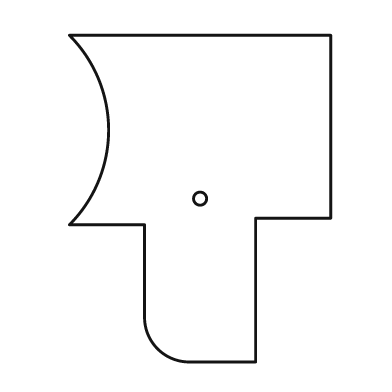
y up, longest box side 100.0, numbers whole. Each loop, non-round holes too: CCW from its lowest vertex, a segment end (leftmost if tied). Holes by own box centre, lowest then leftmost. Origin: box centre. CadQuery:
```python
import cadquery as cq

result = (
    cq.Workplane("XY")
    .moveTo(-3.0, -50.0)
    .lineTo(17.0, -50.0)
    .lineTo(17.0, -6.0)
    .lineTo(40.0, -6.0)
    .lineTo(40.0, 50.0)
    .lineTo(-40.0, 50.0)
    .threePointArc((-28.0, 21.0), (-40.0, -8.0))
    .lineTo(-17.0, -8.0)
    .lineTo(-17.0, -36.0)
    .threePointArc((-13.0, -46.0), (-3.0, -50.0))
    .close()
    .moveTo(0.0, 0.0)
    .circle(2.0)
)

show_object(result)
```